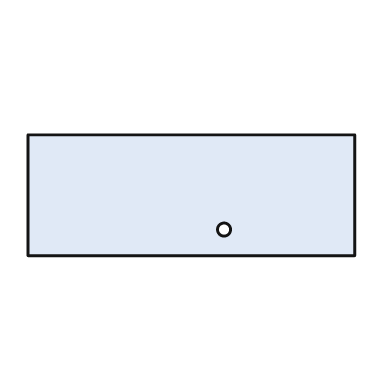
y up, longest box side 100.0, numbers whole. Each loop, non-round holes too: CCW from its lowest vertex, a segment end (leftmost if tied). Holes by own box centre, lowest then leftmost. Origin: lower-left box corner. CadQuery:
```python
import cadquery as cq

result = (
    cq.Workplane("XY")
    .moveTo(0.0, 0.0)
    .lineTo(100.0, 0.0)
    .lineTo(100.0, 37.0)
    .lineTo(0.0, 37.0)
    .close()
    .moveTo(60.0, 8.0)
    .circle(2.0)
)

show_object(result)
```